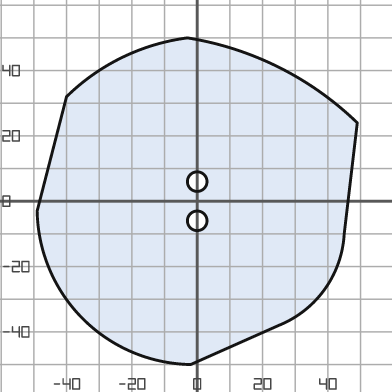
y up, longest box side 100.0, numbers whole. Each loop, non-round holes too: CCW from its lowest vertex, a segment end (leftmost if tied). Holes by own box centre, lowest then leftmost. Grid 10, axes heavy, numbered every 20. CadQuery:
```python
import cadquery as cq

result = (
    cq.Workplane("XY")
    .moveTo(-2.0, -50.0)
    .lineTo(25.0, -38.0)
    .threePointArc((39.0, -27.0), (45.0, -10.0))
    .lineTo(49.0, 24.0)
    .threePointArc((25.0, 41.0), (-3.0, 50.0))
    .threePointArc((-23.0, 44.0), (-40.0, 32.0))
    .lineTo(-49.0, -3.0)
    .threePointArc((-35.0, -36.0), (-2.0, -50.0))
    .close()
    .moveTo(0.0, -6.0)
    .circle(3.0)
    .moveTo(0.0, 6.0)
    .circle(3.0)
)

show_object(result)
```